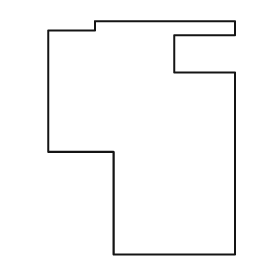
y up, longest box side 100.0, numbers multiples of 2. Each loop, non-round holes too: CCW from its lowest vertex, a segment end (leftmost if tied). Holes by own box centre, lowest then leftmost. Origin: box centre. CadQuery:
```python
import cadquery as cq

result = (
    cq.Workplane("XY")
    .moveTo(-12.0, -50.0)
    .lineTo(40.0, -50.0)
    .lineTo(40.0, 28.0)
    .lineTo(14.0, 28.0)
    .lineTo(14.0, 44.0)
    .lineTo(40.0, 44.0)
    .lineTo(40.0, 50.0)
    .lineTo(-20.0, 50.0)
    .lineTo(-20.0, 46.0)
    .lineTo(-40.0, 46.0)
    .lineTo(-40.0, -6.0)
    .lineTo(-12.0, -6.0)
    .close()
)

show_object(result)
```